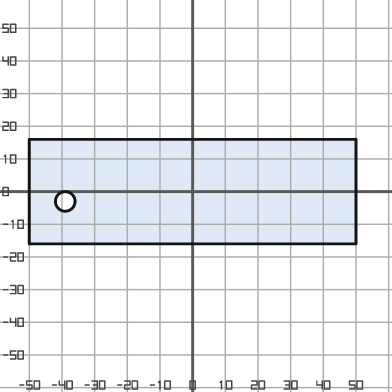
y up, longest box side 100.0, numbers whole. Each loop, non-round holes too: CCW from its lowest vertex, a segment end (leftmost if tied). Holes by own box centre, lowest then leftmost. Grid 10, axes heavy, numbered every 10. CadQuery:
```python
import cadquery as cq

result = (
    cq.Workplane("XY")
    .moveTo(-50.0, -16.0)
    .lineTo(50.0, -16.0)
    .lineTo(50.0, 16.0)
    .lineTo(-50.0, 16.0)
    .close()
    .moveTo(-39.0, -3.0)
    .circle(3.0)
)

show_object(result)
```